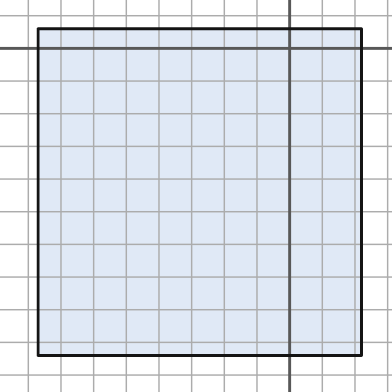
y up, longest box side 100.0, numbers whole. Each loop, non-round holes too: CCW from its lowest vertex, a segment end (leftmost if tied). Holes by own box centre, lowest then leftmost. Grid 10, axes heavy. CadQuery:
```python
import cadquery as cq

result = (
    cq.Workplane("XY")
    .moveTo(-77.0, -94.0)
    .lineTo(22.0, -94.0)
    .lineTo(22.0, 6.0)
    .lineTo(-77.0, 6.0)
    .close()
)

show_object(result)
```